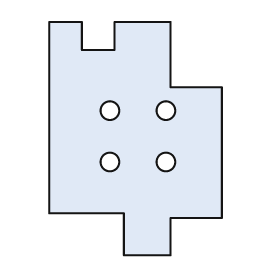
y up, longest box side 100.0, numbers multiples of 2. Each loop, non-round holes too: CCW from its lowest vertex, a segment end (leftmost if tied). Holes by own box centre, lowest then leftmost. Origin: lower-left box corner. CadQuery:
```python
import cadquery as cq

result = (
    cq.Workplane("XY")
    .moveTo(32.0, 0.0)
    .lineTo(52.0, 0.0)
    .lineTo(52.0, 16.0)
    .lineTo(74.0, 16.0)
    .lineTo(74.0, 72.0)
    .lineTo(52.0, 72.0)
    .lineTo(52.0, 100.0)
    .lineTo(28.0, 100.0)
    .lineTo(28.0, 88.0)
    .lineTo(14.0, 88.0)
    .lineTo(14.0, 100.0)
    .lineTo(0.0, 100.0)
    .lineTo(0.0, 18.0)
    .lineTo(32.0, 18.0)
    .close()
    .moveTo(26.0, 40.0)
    .circle(4.0)
    .moveTo(50.0, 40.0)
    .circle(4.0)
    .moveTo(26.0, 62.0)
    .circle(4.0)
    .moveTo(50.0, 62.0)
    .circle(4.0)
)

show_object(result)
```